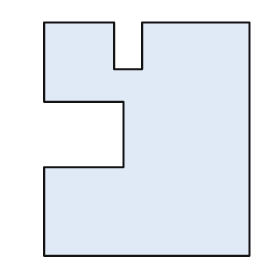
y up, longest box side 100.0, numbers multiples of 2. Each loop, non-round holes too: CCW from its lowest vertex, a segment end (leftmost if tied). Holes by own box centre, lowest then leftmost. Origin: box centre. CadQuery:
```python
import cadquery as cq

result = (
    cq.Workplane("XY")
    .moveTo(-44.0, -50.0)
    .lineTo(44.0, -50.0)
    .lineTo(44.0, 50.0)
    .lineTo(-2.0, 50.0)
    .lineTo(-2.0, 30.0)
    .lineTo(-14.0, 30.0)
    .lineTo(-14.0, 50.0)
    .lineTo(-44.0, 50.0)
    .lineTo(-44.0, 16.0)
    .lineTo(-10.0, 16.0)
    .lineTo(-10.0, -12.0)
    .lineTo(-44.0, -12.0)
    .close()
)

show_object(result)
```